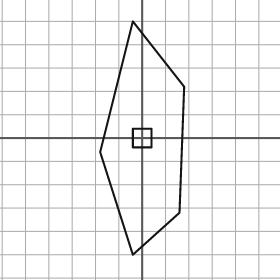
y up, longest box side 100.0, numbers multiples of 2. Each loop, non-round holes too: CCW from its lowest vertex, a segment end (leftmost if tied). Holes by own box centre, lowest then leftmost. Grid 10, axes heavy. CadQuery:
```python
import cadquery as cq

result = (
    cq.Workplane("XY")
    .moveTo(-4.0, -50.0)
    .lineTo(16.0, -32.0)
    .lineTo(18.0, 22.0)
    .lineTo(-4.0, 50.0)
    .lineTo(-18.0, -6.0)
    .close()
    .moveTo(-4.0, -4.0)
    .lineTo(4.0, -4.0)
    .lineTo(4.0, 4.0)
    .lineTo(-4.0, 4.0)
    .close()
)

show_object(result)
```